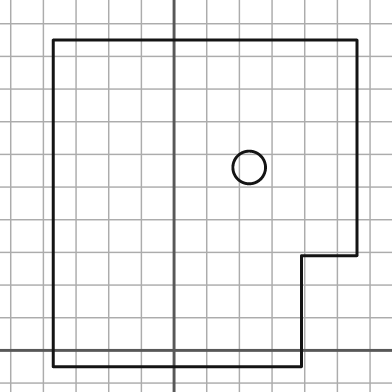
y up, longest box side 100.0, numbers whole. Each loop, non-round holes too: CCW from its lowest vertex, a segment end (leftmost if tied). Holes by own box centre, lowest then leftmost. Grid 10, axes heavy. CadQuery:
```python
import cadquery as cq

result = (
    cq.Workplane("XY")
    .moveTo(-37.0, -5.0)
    .lineTo(39.0, -5.0)
    .lineTo(39.0, 29.0)
    .lineTo(56.0, 29.0)
    .lineTo(56.0, 95.0)
    .lineTo(-37.0, 95.0)
    .close()
    .moveTo(23.0, 56.0)
    .circle(5.0)
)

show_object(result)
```